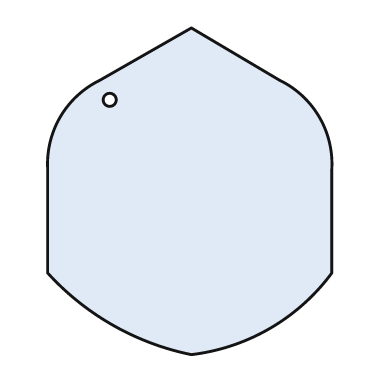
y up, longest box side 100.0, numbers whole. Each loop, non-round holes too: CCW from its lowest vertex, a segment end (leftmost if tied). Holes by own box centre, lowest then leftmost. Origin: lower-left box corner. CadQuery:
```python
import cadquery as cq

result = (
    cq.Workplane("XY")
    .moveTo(44.0, 0.0)
    .threePointArc((68.0, 8.0), (87.0, 25.0))
    .lineTo(87.0, 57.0)
    .threePointArc((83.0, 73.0), (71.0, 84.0))
    .lineTo(44.0, 100.0)
    .lineTo(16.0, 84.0)
    .threePointArc((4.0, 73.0), (0.0, 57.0))
    .lineTo(0.0, 25.0)
    .threePointArc((20.0, 9.0), (44.0, 0.0))
    .close()
    .moveTo(19.0, 78.0)
    .circle(2.0)
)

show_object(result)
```